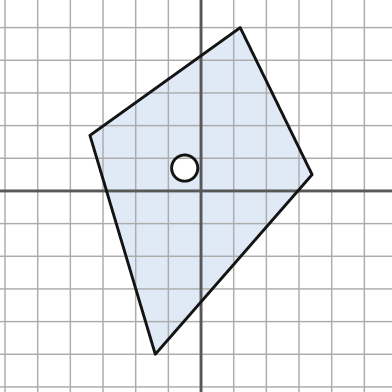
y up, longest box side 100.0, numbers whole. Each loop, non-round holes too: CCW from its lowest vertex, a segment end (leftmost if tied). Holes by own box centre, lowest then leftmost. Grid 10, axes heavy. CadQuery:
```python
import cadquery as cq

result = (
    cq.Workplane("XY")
    .moveTo(-14.0, -50.0)
    .lineTo(34.0, 5.0)
    .lineTo(12.0, 50.0)
    .lineTo(-34.0, 17.0)
    .close()
    .moveTo(-5.0, 7.0)
    .circle(4.0)
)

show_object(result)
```